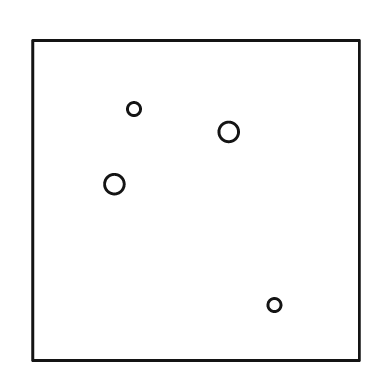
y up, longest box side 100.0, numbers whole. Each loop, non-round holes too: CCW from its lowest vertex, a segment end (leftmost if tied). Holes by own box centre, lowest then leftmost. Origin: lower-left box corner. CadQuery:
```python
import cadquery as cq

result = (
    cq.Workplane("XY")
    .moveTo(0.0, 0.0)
    .lineTo(100.0, 0.0)
    .lineTo(100.0, 98.0)
    .lineTo(0.0, 98.0)
    .close()
    .moveTo(74.0, 17.0)
    .circle(2.0)
    .moveTo(25.0, 54.0)
    .circle(3.0)
    .moveTo(60.0, 70.0)
    .circle(3.0)
    .moveTo(31.0, 77.0)
    .circle(2.0)
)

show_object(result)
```